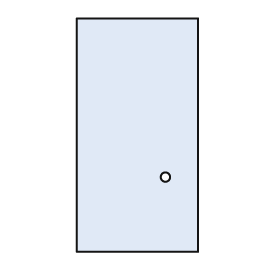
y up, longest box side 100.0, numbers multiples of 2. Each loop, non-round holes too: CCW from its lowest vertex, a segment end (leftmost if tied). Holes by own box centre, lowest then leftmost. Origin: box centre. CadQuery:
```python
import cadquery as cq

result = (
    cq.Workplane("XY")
    .moveTo(-26.0, -50.0)
    .lineTo(26.0, -50.0)
    .lineTo(26.0, 50.0)
    .lineTo(-26.0, 50.0)
    .close()
    .moveTo(12.0, -18.0)
    .circle(2.0)
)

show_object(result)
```